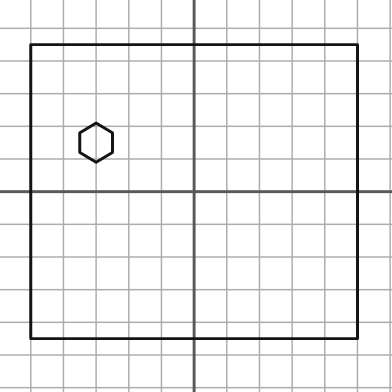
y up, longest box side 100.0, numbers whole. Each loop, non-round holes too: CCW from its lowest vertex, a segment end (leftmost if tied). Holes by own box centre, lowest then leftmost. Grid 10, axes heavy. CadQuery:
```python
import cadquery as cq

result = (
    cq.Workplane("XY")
    .moveTo(-50.0, -45.0)
    .lineTo(50.0, -45.0)
    .lineTo(50.0, 45.0)
    .lineTo(-50.0, 45.0)
    .close()
    .moveTo(-30.0, 9.0)
    .lineTo(-25.0, 12.0)
    .lineTo(-25.0, 18.0)
    .lineTo(-30.0, 21.0)
    .lineTo(-35.0, 18.0)
    .lineTo(-35.0, 12.0)
    .close()
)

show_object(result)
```